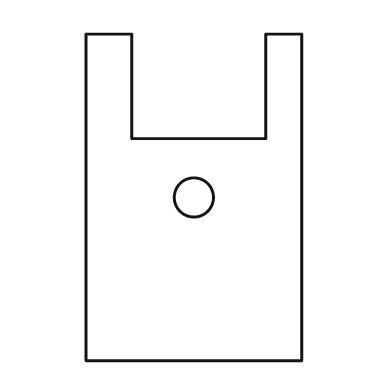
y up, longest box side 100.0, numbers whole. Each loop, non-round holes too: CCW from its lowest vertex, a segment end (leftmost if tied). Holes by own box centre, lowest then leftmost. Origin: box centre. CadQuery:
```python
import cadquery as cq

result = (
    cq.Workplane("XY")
    .moveTo(-33.0, -50.0)
    .lineTo(33.0, -50.0)
    .lineTo(33.0, 50.0)
    .lineTo(22.0, 50.0)
    .lineTo(22.0, 18.0)
    .lineTo(-19.0, 18.0)
    .lineTo(-19.0, 50.0)
    .lineTo(-33.0, 50.0)
    .close()
    .moveTo(0.0, 0.0)
    .circle(6.0)
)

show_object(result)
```